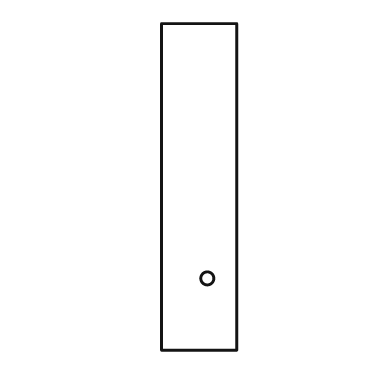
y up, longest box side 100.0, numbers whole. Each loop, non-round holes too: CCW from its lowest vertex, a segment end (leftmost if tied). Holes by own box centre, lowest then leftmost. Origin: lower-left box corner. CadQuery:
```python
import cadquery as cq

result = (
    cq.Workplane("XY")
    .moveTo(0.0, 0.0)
    .lineTo(23.0, 0.0)
    .lineTo(23.0, 100.0)
    .lineTo(0.0, 100.0)
    .close()
    .moveTo(14.0, 22.0)
    .circle(2.0)
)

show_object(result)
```